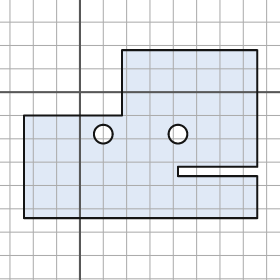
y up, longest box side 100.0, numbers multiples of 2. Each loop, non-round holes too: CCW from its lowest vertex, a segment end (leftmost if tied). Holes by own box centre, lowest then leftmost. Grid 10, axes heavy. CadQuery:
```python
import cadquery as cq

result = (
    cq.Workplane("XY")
    .moveTo(-24.0, -54.0)
    .lineTo(76.0, -54.0)
    .lineTo(76.0, -36.0)
    .lineTo(42.0, -36.0)
    .lineTo(42.0, -32.0)
    .lineTo(76.0, -32.0)
    .lineTo(76.0, 18.0)
    .lineTo(18.0, 18.0)
    .lineTo(18.0, -10.0)
    .lineTo(-24.0, -10.0)
    .close()
    .moveTo(10.0, -18.0)
    .circle(4.0)
    .moveTo(42.0, -18.0)
    .circle(4.0)
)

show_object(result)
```